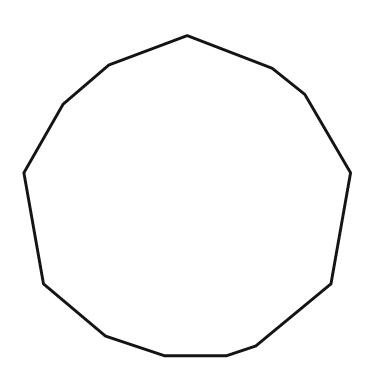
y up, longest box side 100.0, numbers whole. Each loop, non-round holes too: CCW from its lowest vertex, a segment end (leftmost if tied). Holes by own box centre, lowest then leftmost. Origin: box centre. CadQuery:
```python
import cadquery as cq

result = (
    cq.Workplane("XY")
    .moveTo(-7.0, -49.0)
    .lineTo(12.0, -49.0)
    .lineTo(21.0, -46.0)
    .lineTo(44.0, -27.0)
    .lineTo(50.0, 7.0)
    .lineTo(36.0, 31.0)
    .lineTo(26.0, 39.0)
    .lineTo(0.0, 49.0)
    .lineTo(-24.0, 40.0)
    .lineTo(-38.0, 28.0)
    .lineTo(-50.0, 7.0)
    .lineTo(-44.0, -27.0)
    .lineTo(-25.0, -43.0)
    .close()
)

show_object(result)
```